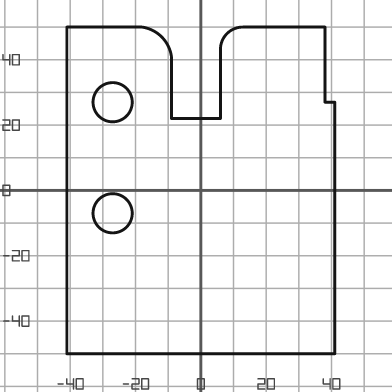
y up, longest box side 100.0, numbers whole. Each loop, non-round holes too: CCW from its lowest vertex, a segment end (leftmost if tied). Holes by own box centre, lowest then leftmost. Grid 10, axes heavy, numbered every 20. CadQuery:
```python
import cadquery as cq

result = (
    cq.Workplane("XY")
    .moveTo(-41.0, -50.0)
    .lineTo(41.0, -50.0)
    .lineTo(41.0, 27.0)
    .lineTo(38.0, 27.0)
    .lineTo(38.0, 50.0)
    .lineTo(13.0, 50.0)
    .threePointArc((8.0, 48.0), (6.0, 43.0))
    .lineTo(6.0, 22.0)
    .lineTo(-9.0, 22.0)
    .lineTo(-9.0, 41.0)
    .threePointArc((-12.0, 47.0), (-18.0, 50.0))
    .lineTo(-41.0, 50.0)
    .close()
    .moveTo(-27.0, -7.0)
    .circle(6.0)
    .moveTo(-27.0, 27.0)
    .circle(6.0)
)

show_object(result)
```